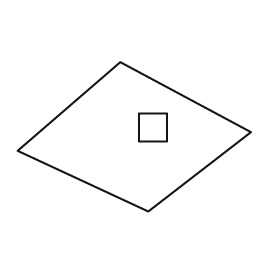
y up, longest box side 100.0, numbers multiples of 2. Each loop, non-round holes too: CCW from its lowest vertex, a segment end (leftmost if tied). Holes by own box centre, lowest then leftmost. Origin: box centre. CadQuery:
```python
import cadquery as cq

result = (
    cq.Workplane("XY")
    .moveTo(6.0, -32.0)
    .lineTo(50.0, 2.0)
    .lineTo(-6.0, 32.0)
    .lineTo(-50.0, -6.0)
    .close()
    .moveTo(2.0, -2.0)
    .lineTo(14.0, -2.0)
    .lineTo(14.0, 10.0)
    .lineTo(2.0, 10.0)
    .close()
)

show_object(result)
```